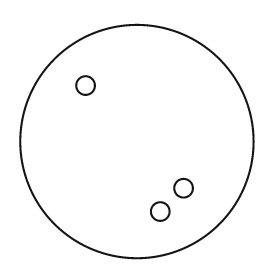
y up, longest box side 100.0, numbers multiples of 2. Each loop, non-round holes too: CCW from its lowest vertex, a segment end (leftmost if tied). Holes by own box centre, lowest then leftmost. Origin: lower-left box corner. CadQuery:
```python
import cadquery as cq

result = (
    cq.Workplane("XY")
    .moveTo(50.0, 50.0)
    .circle(50.0)
    .moveTo(60.0, 20.0)
    .circle(4.0)
    .moveTo(70.0, 30.0)
    .circle(4.0)
    .moveTo(28.0, 74.0)
    .circle(4.0)
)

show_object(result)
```